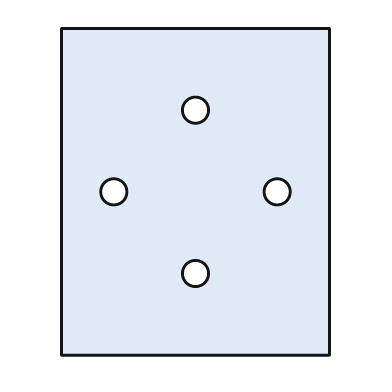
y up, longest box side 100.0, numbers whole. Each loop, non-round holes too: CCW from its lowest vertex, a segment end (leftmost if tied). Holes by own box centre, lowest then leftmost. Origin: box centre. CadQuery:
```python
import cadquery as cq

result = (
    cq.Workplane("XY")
    .moveTo(-41.0, -50.0)
    .lineTo(41.0, -50.0)
    .lineTo(41.0, 50.0)
    .lineTo(-41.0, 50.0)
    .close()
    .moveTo(0.0, -25.0)
    .circle(4.0)
    .moveTo(-25.0, 0.0)
    .circle(4.0)
    .moveTo(25.0, 0.0)
    .circle(4.0)
    .moveTo(0.0, 25.0)
    .circle(4.0)
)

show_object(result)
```